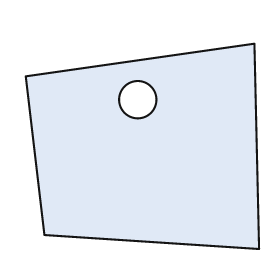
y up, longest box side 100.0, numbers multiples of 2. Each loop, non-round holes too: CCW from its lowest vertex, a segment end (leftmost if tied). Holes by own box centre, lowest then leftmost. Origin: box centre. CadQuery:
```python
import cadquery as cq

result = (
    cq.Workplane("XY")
    .moveTo(50.0, -44.0)
    .lineTo(48.0, 44.0)
    .lineTo(-50.0, 30.0)
    .lineTo(-42.0, -38.0)
    .close()
    .moveTo(-2.0, 20.0)
    .circle(8.0)
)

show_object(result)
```